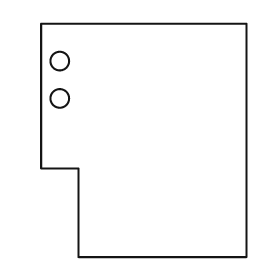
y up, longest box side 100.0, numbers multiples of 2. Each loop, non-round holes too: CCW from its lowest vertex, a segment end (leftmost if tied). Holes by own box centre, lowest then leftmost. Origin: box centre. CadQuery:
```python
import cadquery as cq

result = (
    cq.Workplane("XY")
    .moveTo(-28.0, -50.0)
    .lineTo(44.0, -50.0)
    .lineTo(44.0, 50.0)
    .lineTo(-44.0, 50.0)
    .lineTo(-44.0, -12.0)
    .lineTo(-28.0, -12.0)
    .close()
    .moveTo(-36.0, 18.0)
    .circle(4.0)
    .moveTo(-36.0, 34.0)
    .circle(4.0)
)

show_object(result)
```